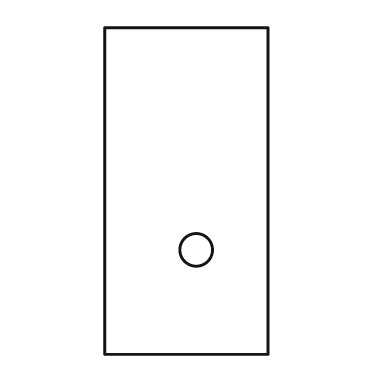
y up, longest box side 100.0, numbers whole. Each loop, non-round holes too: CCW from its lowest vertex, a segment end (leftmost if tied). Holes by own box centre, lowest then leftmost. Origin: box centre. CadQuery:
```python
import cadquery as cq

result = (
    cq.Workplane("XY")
    .moveTo(-25.0, -50.0)
    .lineTo(25.0, -50.0)
    .lineTo(25.0, 50.0)
    .lineTo(-25.0, 50.0)
    .close()
    .moveTo(3.0, -18.0)
    .circle(5.0)
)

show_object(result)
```